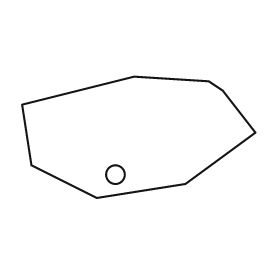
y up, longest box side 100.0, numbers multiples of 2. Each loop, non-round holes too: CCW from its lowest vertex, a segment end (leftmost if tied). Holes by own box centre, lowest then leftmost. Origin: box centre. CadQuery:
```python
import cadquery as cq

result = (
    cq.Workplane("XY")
    .moveTo(-18.0, -26.0)
    .lineTo(20.0, -20.0)
    .lineTo(50.0, 2.0)
    .lineTo(36.0, 20.0)
    .lineTo(30.0, 24.0)
    .lineTo(-2.0, 26.0)
    .lineTo(-50.0, 14.0)
    .lineTo(-46.0, -12.0)
    .close()
    .moveTo(-10.0, -16.0)
    .circle(4.0)
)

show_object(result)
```